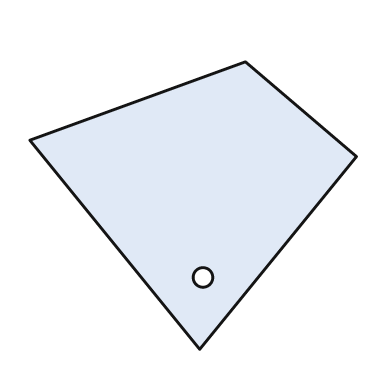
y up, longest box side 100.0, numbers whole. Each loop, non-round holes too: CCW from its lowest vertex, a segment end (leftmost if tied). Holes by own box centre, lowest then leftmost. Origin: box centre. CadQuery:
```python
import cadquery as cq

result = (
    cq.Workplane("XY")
    .moveTo(2.0, -44.0)
    .lineTo(50.0, 15.0)
    .lineTo(16.0, 44.0)
    .lineTo(-50.0, 20.0)
    .close()
    .moveTo(3.0, -22.0)
    .circle(3.0)
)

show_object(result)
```